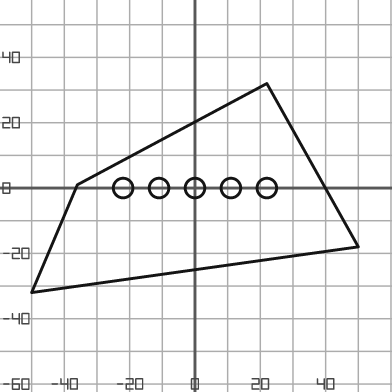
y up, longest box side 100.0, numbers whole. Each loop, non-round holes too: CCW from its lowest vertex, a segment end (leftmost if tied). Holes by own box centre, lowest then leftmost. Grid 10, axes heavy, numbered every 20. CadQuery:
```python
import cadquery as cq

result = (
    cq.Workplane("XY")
    .moveTo(-50.0, -32.0)
    .lineTo(50.0, -18.0)
    .lineTo(22.0, 32.0)
    .lineTo(-36.0, 1.0)
    .close()
    .moveTo(-22.0, 0.0)
    .circle(3.0)
    .moveTo(-11.0, 0.0)
    .circle(3.0)
    .moveTo(0.0, 0.0)
    .circle(3.0)
    .moveTo(11.0, 0.0)
    .circle(3.0)
    .moveTo(22.0, 0.0)
    .circle(3.0)
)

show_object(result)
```